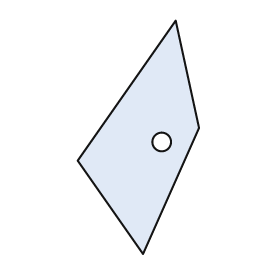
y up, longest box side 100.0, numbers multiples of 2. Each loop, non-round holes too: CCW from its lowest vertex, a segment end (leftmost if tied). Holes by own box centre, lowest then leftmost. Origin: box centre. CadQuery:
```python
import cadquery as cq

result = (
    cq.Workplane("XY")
    .moveTo(2.0, -50.0)
    .lineTo(26.0, 4.0)
    .lineTo(16.0, 50.0)
    .lineTo(-26.0, -10.0)
    .close()
    .moveTo(10.0, -2.0)
    .circle(4.0)
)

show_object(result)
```